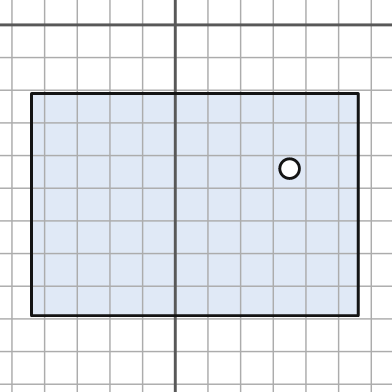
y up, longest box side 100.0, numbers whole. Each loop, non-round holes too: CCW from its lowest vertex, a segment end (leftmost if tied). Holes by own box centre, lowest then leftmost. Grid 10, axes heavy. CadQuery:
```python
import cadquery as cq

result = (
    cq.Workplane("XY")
    .moveTo(-44.0, -89.0)
    .lineTo(56.0, -89.0)
    .lineTo(56.0, -21.0)
    .lineTo(-44.0, -21.0)
    .close()
    .moveTo(35.0, -44.0)
    .circle(3.0)
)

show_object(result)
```